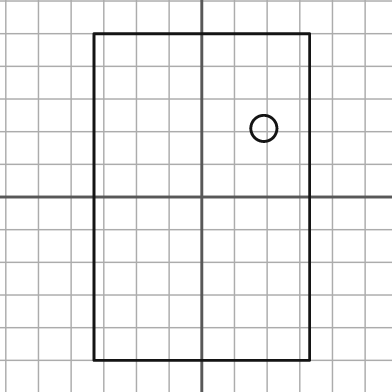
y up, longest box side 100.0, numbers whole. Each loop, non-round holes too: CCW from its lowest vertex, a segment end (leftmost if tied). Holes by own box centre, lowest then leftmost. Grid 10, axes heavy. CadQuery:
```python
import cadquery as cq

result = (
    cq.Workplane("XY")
    .moveTo(-33.0, -50.0)
    .lineTo(33.0, -50.0)
    .lineTo(33.0, 50.0)
    .lineTo(-33.0, 50.0)
    .close()
    .moveTo(19.0, 21.0)
    .circle(4.0)
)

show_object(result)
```